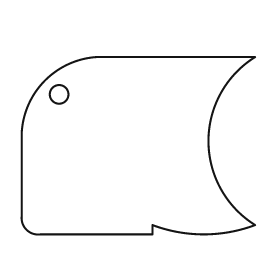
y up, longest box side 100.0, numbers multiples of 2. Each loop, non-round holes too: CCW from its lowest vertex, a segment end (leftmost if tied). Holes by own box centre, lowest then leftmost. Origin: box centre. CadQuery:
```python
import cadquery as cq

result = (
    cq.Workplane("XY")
    .moveTo(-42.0, -38.0)
    .lineTo(6.0, -38.0)
    .lineTo(6.0, -34.0)
    .threePointArc((28.0, -38.0), (50.0, -34.0))
    .threePointArc((30.0, 2.0), (50.0, 38.0))
    .lineTo(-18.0, 38.0)
    .threePointArc((-40.0, 28.0), (-50.0, 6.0))
    .lineTo(-50.0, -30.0)
    .threePointArc((-48.0, -36.0), (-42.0, -38.0))
    .close()
    .moveTo(-34.0, 22.0)
    .circle(4.0)
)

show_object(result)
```